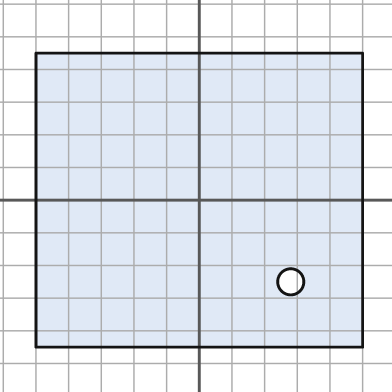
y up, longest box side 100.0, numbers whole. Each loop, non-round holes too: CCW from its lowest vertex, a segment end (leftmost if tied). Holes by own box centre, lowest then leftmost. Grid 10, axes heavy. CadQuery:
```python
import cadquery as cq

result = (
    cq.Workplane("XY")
    .moveTo(-50.0, -45.0)
    .lineTo(50.0, -45.0)
    .lineTo(50.0, 45.0)
    .lineTo(-50.0, 45.0)
    .close()
    .moveTo(28.0, -25.0)
    .circle(4.0)
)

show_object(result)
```